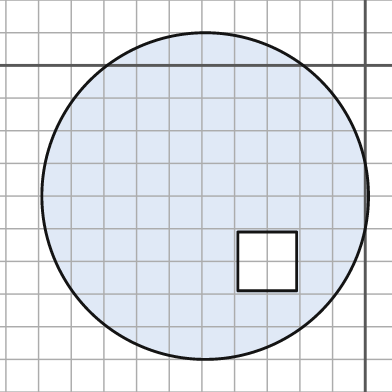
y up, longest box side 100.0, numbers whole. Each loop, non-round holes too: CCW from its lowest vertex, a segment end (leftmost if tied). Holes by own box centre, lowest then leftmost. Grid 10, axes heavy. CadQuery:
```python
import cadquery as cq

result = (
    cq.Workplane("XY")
    .moveTo(-49.0, -40.0)
    .circle(50.0)
    .moveTo(-39.0, -69.0)
    .lineTo(-21.0, -69.0)
    .lineTo(-21.0, -51.0)
    .lineTo(-39.0, -51.0)
    .close()
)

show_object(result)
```